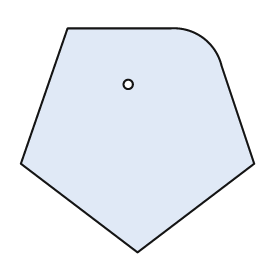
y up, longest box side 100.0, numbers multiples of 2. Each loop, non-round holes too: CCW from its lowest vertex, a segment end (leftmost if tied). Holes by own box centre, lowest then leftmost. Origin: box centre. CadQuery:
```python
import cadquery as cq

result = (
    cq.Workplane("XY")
    .moveTo(0.0, -48.0)
    .lineTo(50.0, -10.0)
    .lineTo(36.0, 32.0)
    .threePointArc((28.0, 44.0), (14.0, 48.0))
    .lineTo(-30.0, 48.0)
    .lineTo(-50.0, -10.0)
    .close()
    .moveTo(-4.0, 24.0)
    .circle(2.0)
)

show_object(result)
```